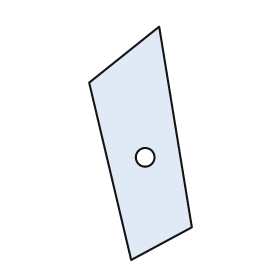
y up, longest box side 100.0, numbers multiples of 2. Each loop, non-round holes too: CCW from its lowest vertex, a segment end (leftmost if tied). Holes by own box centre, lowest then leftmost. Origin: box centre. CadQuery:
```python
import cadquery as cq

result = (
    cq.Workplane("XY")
    .moveTo(-4.0, -50.0)
    .lineTo(22.0, -36.0)
    .lineTo(8.0, 50.0)
    .lineTo(-22.0, 26.0)
    .close()
    .moveTo(2.0, -6.0)
    .circle(4.0)
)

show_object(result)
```